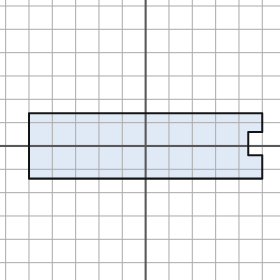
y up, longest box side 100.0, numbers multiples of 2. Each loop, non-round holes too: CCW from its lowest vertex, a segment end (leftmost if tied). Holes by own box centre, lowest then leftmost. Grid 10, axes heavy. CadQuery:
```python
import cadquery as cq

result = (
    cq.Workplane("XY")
    .moveTo(-50.0, -14.0)
    .lineTo(50.0, -14.0)
    .lineTo(50.0, -4.0)
    .lineTo(44.0, -4.0)
    .lineTo(44.0, 6.0)
    .lineTo(50.0, 6.0)
    .lineTo(50.0, 14.0)
    .lineTo(-50.0, 14.0)
    .close()
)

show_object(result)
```